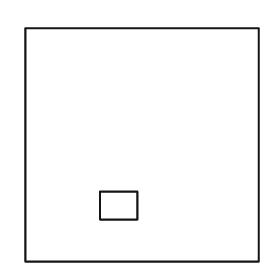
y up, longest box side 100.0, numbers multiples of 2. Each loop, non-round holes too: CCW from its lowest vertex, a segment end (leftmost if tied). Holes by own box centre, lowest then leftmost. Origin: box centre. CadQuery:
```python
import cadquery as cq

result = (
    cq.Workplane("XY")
    .moveTo(-50.0, -50.0)
    .lineTo(50.0, -50.0)
    .lineTo(50.0, 50.0)
    .lineTo(-50.0, 50.0)
    .close()
    .moveTo(-18.0, -32.0)
    .lineTo(-2.0, -32.0)
    .lineTo(-2.0, -20.0)
    .lineTo(-18.0, -20.0)
    .close()
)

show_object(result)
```